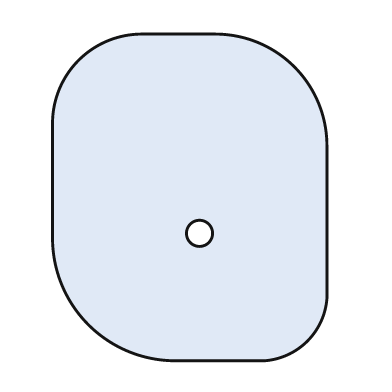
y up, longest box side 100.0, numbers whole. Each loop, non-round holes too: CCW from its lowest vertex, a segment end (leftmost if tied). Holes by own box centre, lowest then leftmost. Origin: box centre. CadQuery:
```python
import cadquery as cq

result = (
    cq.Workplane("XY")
    .moveTo(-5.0, -50.0)
    .lineTo(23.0, -50.0)
    .threePointArc((36.0, -44.0), (42.0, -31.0))
    .lineTo(42.0, 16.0)
    .threePointArc((32.0, 40.0), (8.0, 50.0))
    .lineTo(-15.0, 50.0)
    .threePointArc((-34.0, 42.0), (-42.0, 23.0))
    .lineTo(-42.0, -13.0)
    .threePointArc((-31.0, -39.0), (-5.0, -50.0))
    .close()
    .moveTo(3.0, -11.0)
    .circle(4.0)
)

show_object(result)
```